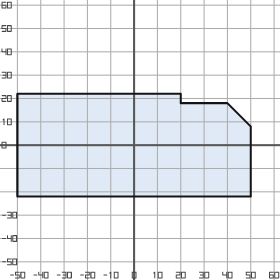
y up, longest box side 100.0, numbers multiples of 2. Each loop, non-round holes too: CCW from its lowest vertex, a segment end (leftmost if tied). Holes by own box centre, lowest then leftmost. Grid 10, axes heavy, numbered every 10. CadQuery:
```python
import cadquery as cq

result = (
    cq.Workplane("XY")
    .moveTo(-50.0, -22.0)
    .lineTo(50.0, -22.0)
    .lineTo(50.0, 8.0)
    .lineTo(40.0, 18.0)
    .lineTo(20.0, 18.0)
    .lineTo(20.0, 22.0)
    .lineTo(-50.0, 22.0)
    .close()
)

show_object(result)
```